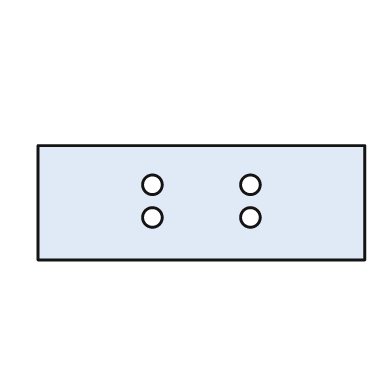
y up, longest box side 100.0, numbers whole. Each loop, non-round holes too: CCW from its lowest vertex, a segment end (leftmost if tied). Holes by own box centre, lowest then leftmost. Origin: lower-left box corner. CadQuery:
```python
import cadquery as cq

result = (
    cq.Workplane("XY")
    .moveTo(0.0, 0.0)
    .lineTo(100.0, 0.0)
    .lineTo(100.0, 35.0)
    .lineTo(0.0, 35.0)
    .close()
    .moveTo(35.0, 13.0)
    .circle(3.0)
    .moveTo(65.0, 13.0)
    .circle(3.0)
    .moveTo(35.0, 23.0)
    .circle(3.0)
    .moveTo(65.0, 23.0)
    .circle(3.0)
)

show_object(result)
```